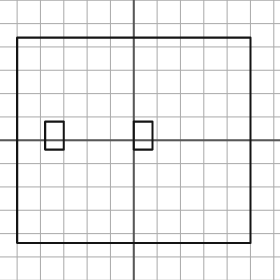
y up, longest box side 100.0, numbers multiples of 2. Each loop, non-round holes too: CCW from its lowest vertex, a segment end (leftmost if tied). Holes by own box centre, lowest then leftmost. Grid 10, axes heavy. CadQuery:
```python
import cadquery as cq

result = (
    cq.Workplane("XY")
    .moveTo(-50.0, -44.0)
    .lineTo(50.0, -44.0)
    .lineTo(50.0, 44.0)
    .lineTo(-50.0, 44.0)
    .close()
    .moveTo(-38.0, -4.0)
    .lineTo(-30.0, -4.0)
    .lineTo(-30.0, 8.0)
    .lineTo(-38.0, 8.0)
    .close()
    .moveTo(0.0, -4.0)
    .lineTo(8.0, -4.0)
    .lineTo(8.0, 8.0)
    .lineTo(0.0, 8.0)
    .close()
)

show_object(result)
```